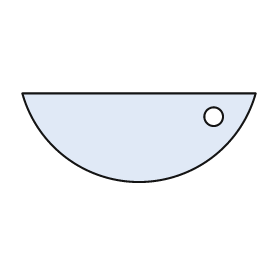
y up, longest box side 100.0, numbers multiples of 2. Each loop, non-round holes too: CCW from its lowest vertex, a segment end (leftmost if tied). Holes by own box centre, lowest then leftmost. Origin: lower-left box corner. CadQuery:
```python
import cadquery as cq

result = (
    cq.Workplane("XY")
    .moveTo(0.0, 38.0)
    .threePointArc((50.0, 0.0), (100.0, 38.0))
    .close()
    .moveTo(82.0, 28.0)
    .circle(4.0)
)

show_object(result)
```